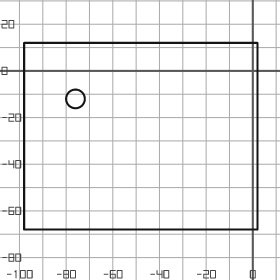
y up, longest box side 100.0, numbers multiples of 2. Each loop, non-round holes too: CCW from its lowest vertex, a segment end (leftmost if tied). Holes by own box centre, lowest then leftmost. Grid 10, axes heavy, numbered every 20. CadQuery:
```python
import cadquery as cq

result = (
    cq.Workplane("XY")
    .moveTo(-98.0, -68.0)
    .lineTo(2.0, -68.0)
    .lineTo(2.0, 12.0)
    .lineTo(-98.0, 12.0)
    .close()
    .moveTo(-76.0, -12.0)
    .circle(4.0)
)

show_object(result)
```